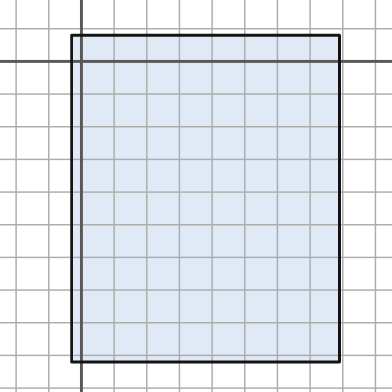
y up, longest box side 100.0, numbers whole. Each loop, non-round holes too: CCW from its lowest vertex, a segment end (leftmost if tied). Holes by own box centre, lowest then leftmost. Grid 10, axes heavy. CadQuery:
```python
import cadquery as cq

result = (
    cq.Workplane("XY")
    .moveTo(-3.0, -92.0)
    .lineTo(79.0, -92.0)
    .lineTo(79.0, 8.0)
    .lineTo(-3.0, 8.0)
    .close()
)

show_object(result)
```